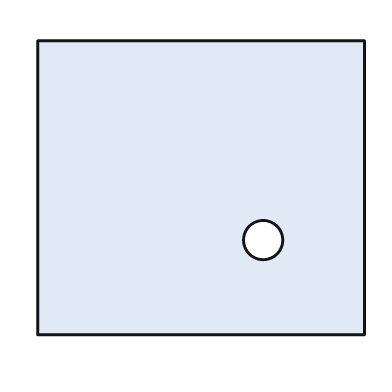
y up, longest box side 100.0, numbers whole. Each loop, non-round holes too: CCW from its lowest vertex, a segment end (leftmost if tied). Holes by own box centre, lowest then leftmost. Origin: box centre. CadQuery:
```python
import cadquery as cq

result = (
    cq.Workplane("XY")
    .moveTo(-50.0, -45.0)
    .lineTo(50.0, -45.0)
    .lineTo(50.0, 45.0)
    .lineTo(-50.0, 45.0)
    .close()
    .moveTo(19.0, -16.0)
    .circle(6.0)
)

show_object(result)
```